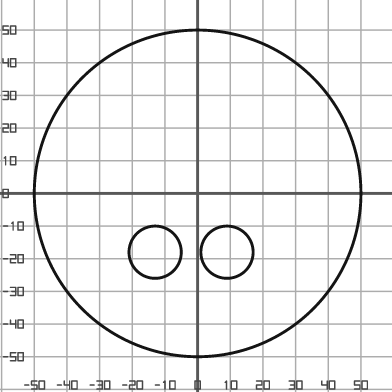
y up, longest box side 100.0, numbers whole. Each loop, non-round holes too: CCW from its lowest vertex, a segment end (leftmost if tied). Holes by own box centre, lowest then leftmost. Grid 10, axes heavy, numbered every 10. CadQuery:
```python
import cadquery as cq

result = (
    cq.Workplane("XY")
    .moveTo(0.0, 0.0)
    .circle(50.0)
    .moveTo(-13.0, -18.0)
    .circle(8.0)
    .moveTo(9.0, -18.0)
    .circle(8.0)
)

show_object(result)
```